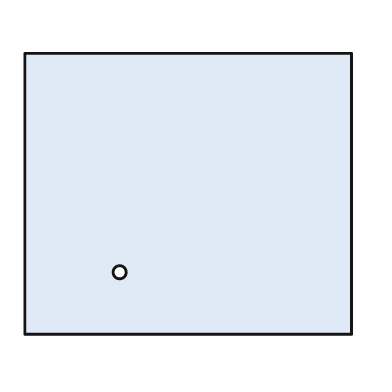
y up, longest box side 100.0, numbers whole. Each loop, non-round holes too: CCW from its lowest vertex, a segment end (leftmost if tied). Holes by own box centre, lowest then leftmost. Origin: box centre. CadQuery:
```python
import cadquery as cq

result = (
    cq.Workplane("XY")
    .moveTo(-50.0, -43.0)
    .lineTo(50.0, -43.0)
    .lineTo(50.0, 43.0)
    .lineTo(-50.0, 43.0)
    .close()
    .moveTo(-21.0, -24.0)
    .circle(2.0)
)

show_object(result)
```